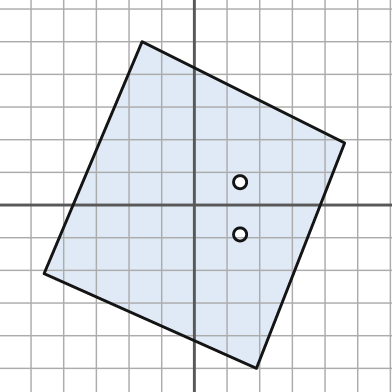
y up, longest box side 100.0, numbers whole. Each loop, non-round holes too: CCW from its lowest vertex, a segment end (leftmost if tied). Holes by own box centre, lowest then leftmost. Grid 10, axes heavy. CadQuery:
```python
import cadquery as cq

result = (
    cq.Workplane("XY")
    .moveTo(19.0, -50.0)
    .lineTo(46.0, 19.0)
    .lineTo(-16.0, 50.0)
    .lineTo(-46.0, -21.0)
    .close()
    .moveTo(14.0, -9.0)
    .circle(2.0)
    .moveTo(14.0, 7.0)
    .circle(2.0)
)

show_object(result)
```